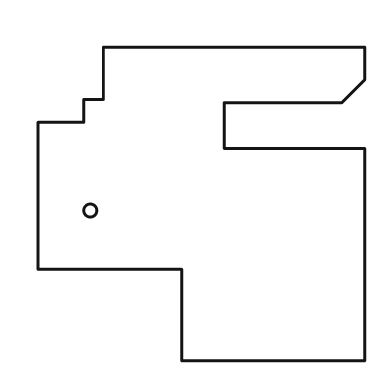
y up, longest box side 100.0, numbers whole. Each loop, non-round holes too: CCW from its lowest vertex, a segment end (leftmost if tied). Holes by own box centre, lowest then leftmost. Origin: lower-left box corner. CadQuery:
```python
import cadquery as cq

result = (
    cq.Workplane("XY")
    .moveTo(44.0, 0.0)
    .lineTo(100.0, 0.0)
    .lineTo(100.0, 65.0)
    .lineTo(57.0, 65.0)
    .lineTo(57.0, 79.0)
    .lineTo(93.0, 79.0)
    .lineTo(100.0, 86.0)
    .lineTo(100.0, 96.0)
    .lineTo(20.0, 96.0)
    .lineTo(20.0, 80.0)
    .lineTo(14.0, 80.0)
    .lineTo(14.0, 73.0)
    .lineTo(0.0, 73.0)
    .lineTo(0.0, 28.0)
    .lineTo(44.0, 28.0)
    .close()
    .moveTo(16.0, 46.0)
    .circle(2.0)
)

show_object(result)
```